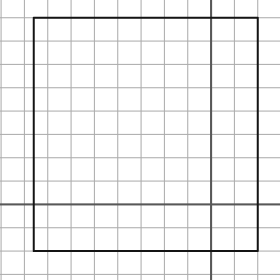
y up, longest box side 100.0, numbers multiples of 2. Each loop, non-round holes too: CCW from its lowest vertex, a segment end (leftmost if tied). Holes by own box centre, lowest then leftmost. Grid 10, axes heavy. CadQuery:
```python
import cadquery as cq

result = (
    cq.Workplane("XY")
    .moveTo(-76.0, -20.0)
    .lineTo(20.0, -20.0)
    .lineTo(20.0, 80.0)
    .lineTo(-76.0, 80.0)
    .close()
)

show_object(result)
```